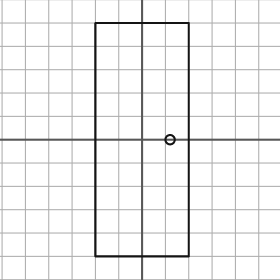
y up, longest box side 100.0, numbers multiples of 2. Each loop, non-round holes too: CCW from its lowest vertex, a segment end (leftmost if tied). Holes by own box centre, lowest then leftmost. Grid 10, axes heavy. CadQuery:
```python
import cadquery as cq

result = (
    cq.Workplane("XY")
    .moveTo(-20.0, -50.0)
    .lineTo(20.0, -50.0)
    .lineTo(20.0, 50.0)
    .lineTo(-20.0, 50.0)
    .close()
    .moveTo(12.0, 0.0)
    .circle(2.0)
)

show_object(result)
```